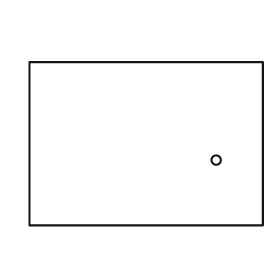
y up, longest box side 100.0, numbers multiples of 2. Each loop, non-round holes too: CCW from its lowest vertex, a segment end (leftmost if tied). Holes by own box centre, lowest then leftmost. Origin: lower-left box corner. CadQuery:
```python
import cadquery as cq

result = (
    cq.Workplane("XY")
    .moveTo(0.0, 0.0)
    .lineTo(100.0, 0.0)
    .lineTo(100.0, 70.0)
    .lineTo(0.0, 70.0)
    .close()
    .moveTo(80.0, 28.0)
    .circle(2.0)
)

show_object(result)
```